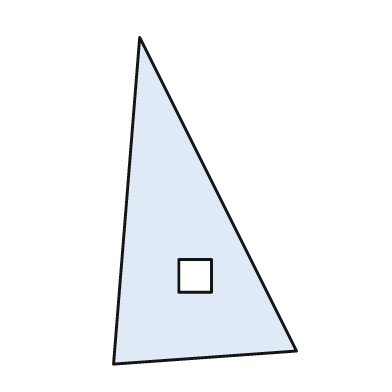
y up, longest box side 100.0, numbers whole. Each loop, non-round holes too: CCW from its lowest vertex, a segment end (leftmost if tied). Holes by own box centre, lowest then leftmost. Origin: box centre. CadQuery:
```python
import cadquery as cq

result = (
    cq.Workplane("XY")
    .moveTo(-28.0, -50.0)
    .lineTo(28.0, -46.0)
    .lineTo(-20.0, 50.0)
    .close()
    .moveTo(-8.0, -28.0)
    .lineTo(2.0, -28.0)
    .lineTo(2.0, -18.0)
    .lineTo(-8.0, -18.0)
    .close()
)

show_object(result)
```